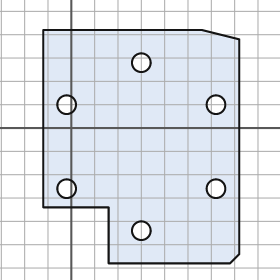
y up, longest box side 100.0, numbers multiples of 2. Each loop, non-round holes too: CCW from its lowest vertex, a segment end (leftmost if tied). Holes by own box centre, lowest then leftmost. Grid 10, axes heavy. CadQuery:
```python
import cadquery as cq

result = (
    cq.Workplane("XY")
    .moveTo(16.0, -58.0)
    .lineTo(68.0, -58.0)
    .lineTo(72.0, -54.0)
    .lineTo(72.0, 38.0)
    .lineTo(56.0, 42.0)
    .lineTo(-12.0, 42.0)
    .lineTo(-12.0, -34.0)
    .lineTo(16.0, -34.0)
    .close()
    .moveTo(30.0, -44.0)
    .circle(4.0)
    .moveTo(-2.0, -26.0)
    .circle(4.0)
    .moveTo(62.0, -26.0)
    .circle(4.0)
    .moveTo(-2.0, 10.0)
    .circle(4.0)
    .moveTo(62.0, 10.0)
    .circle(4.0)
    .moveTo(30.0, 28.0)
    .circle(4.0)
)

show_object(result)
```